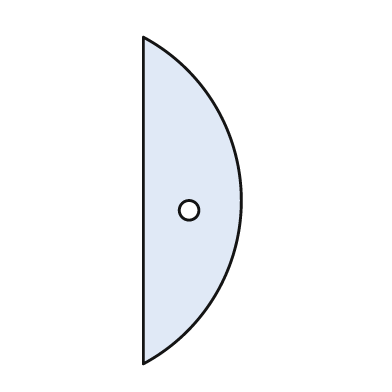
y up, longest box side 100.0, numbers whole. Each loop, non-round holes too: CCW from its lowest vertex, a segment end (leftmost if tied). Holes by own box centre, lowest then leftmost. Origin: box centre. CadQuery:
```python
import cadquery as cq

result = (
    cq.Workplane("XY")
    .moveTo(-15.0, -50.0)
    .threePointArc((15.0, 0.0), (-15.0, 50.0))
    .close()
    .moveTo(-1.0, -3.0)
    .circle(3.0)
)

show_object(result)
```